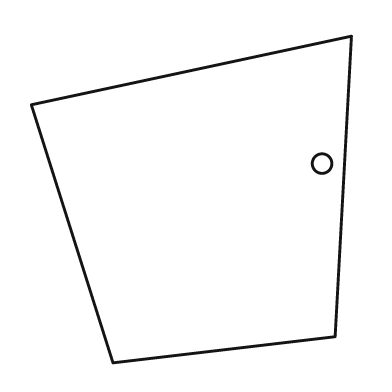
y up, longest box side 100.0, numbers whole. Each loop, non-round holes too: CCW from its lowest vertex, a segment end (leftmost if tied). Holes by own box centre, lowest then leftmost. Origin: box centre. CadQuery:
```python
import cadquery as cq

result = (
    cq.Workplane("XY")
    .moveTo(-24.0, -50.0)
    .lineTo(44.0, -42.0)
    .lineTo(49.0, 50.0)
    .lineTo(-49.0, 29.0)
    .close()
    .moveTo(40.0, 11.0)
    .circle(3.0)
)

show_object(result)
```